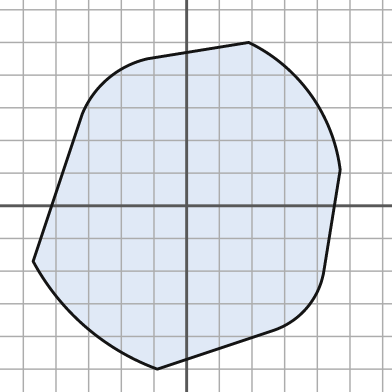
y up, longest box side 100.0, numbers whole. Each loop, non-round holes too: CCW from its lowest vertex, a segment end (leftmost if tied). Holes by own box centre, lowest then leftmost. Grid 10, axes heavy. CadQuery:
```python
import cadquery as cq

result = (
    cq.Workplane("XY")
    .moveTo(-9.0, -50.0)
    .lineTo(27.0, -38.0)
    .threePointArc((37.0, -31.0), (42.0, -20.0))
    .lineTo(47.0, 11.0)
    .threePointArc((38.0, 34.0), (19.0, 50.0))
    .lineTo(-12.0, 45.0)
    .threePointArc((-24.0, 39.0), (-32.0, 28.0))
    .lineTo(-47.0, -17.0)
    .threePointArc((-31.0, -37.0), (-9.0, -50.0))
    .close()
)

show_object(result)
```